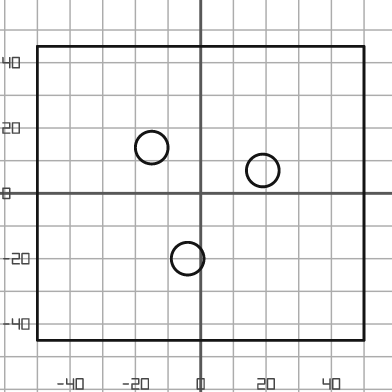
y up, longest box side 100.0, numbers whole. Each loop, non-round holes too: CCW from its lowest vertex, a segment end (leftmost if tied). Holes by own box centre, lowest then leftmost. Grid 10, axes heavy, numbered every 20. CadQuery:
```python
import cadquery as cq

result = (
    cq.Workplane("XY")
    .moveTo(-50.0, -45.0)
    .lineTo(50.0, -45.0)
    .lineTo(50.0, 45.0)
    .lineTo(-50.0, 45.0)
    .close()
    .moveTo(-4.0, -20.0)
    .circle(5.0)
    .moveTo(19.0, 7.0)
    .circle(5.0)
    .moveTo(-15.0, 14.0)
    .circle(5.0)
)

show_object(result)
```